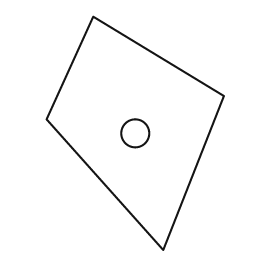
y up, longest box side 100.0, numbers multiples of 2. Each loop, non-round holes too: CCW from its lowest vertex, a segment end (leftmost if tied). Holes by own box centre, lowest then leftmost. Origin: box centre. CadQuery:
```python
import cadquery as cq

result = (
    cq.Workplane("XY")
    .moveTo(12.0, -50.0)
    .lineTo(38.0, 16.0)
    .lineTo(-18.0, 50.0)
    .lineTo(-38.0, 6.0)
    .close()
    .moveTo(0.0, 0.0)
    .circle(6.0)
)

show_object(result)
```